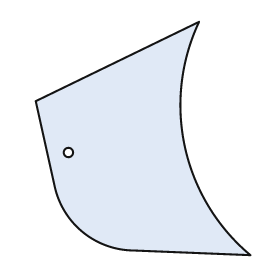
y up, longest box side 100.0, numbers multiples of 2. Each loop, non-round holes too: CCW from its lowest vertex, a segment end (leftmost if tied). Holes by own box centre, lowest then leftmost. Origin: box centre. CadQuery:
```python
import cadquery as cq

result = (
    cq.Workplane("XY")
    .moveTo(46.0, -50.0)
    .threePointArc((18.0, -4.0), (24.0, 50.0))
    .lineTo(-46.0, 16.0)
    .lineTo(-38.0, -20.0)
    .threePointArc((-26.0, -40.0), (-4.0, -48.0))
    .close()
    .moveTo(-32.0, -6.0)
    .circle(2.0)
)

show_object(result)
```